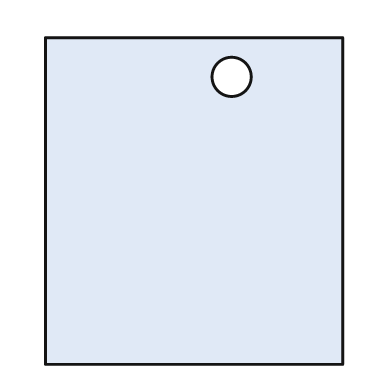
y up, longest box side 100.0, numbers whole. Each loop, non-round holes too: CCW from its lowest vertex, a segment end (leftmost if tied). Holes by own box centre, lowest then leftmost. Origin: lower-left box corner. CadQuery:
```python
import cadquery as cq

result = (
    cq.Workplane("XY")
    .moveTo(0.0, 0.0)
    .lineTo(91.0, 0.0)
    .lineTo(91.0, 100.0)
    .lineTo(0.0, 100.0)
    .close()
    .moveTo(57.0, 88.0)
    .circle(6.0)
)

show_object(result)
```